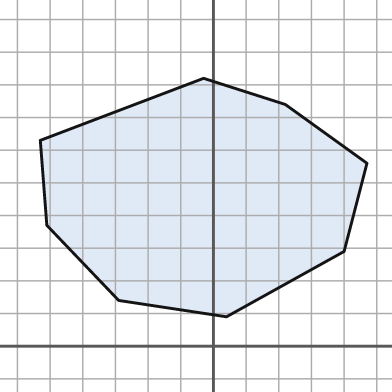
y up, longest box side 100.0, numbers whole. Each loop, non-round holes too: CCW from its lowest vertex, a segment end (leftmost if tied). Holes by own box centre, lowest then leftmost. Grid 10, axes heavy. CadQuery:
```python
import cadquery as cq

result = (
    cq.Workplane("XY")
    .moveTo(4.0, 9.0)
    .lineTo(40.0, 29.0)
    .lineTo(47.0, 56.0)
    .lineTo(22.0, 74.0)
    .lineTo(-3.0, 82.0)
    .lineTo(-53.0, 63.0)
    .lineTo(-51.0, 37.0)
    .lineTo(-29.0, 14.0)
    .close()
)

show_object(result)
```